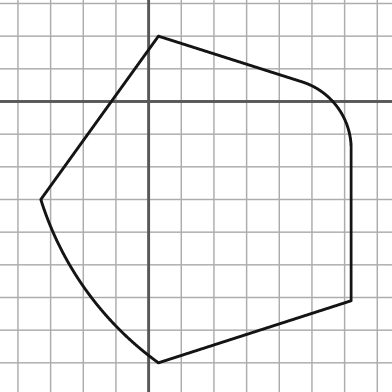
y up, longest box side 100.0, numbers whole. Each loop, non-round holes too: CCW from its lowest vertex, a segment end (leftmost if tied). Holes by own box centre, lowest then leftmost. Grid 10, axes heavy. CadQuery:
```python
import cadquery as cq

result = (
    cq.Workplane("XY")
    .moveTo(3.0, -80.0)
    .lineTo(62.0, -61.0)
    .lineTo(62.0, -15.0)
    .threePointArc((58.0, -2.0), (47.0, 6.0))
    .lineTo(3.0, 20.0)
    .lineTo(-33.0, -30.0)
    .threePointArc((-19.0, -58.0), (3.0, -80.0))
    .close()
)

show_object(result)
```